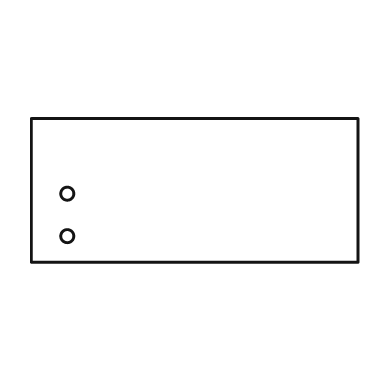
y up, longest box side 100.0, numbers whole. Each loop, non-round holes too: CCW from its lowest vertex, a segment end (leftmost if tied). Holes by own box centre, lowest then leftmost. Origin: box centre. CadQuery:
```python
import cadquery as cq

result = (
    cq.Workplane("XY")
    .moveTo(-50.0, -22.0)
    .lineTo(50.0, -22.0)
    .lineTo(50.0, 22.0)
    .lineTo(-50.0, 22.0)
    .close()
    .moveTo(-39.0, -14.0)
    .circle(2.0)
    .moveTo(-39.0, -1.0)
    .circle(2.0)
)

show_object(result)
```